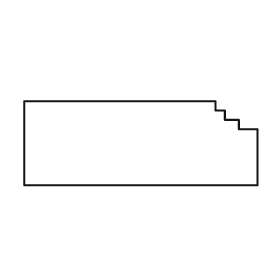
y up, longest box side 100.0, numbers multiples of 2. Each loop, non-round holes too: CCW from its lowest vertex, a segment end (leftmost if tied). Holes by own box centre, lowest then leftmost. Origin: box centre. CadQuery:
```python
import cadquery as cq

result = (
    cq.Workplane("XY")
    .moveTo(-50.0, -18.0)
    .lineTo(50.0, -18.0)
    .lineTo(50.0, 6.0)
    .lineTo(42.0, 6.0)
    .lineTo(42.0, 10.0)
    .lineTo(36.0, 10.0)
    .lineTo(36.0, 14.0)
    .lineTo(32.0, 14.0)
    .lineTo(32.0, 18.0)
    .lineTo(-50.0, 18.0)
    .close()
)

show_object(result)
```